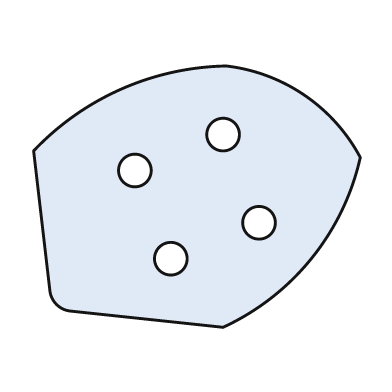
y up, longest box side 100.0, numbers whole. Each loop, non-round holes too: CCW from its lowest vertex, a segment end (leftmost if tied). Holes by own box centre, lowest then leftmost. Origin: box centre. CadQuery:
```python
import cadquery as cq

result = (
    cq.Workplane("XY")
    .moveTo(8.0, -40.0)
    .threePointArc((35.0, -19.0), (50.0, 12.0))
    .threePointArc((33.0, 31.0), (9.0, 40.0))
    .threePointArc((-23.0, 33.0), (-50.0, 14.0))
    .lineTo(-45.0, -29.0)
    .threePointArc((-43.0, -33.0), (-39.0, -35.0))
    .close()
    .moveTo(-8.0, -19.0)
    .circle(5.0)
    .moveTo(19.0, -8.0)
    .circle(5.0)
    .moveTo(-19.0, 8.0)
    .circle(5.0)
    .moveTo(8.0, 19.0)
    .circle(5.0)
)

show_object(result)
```